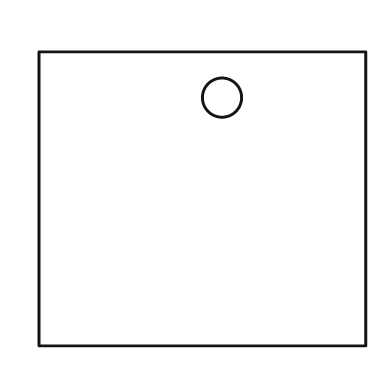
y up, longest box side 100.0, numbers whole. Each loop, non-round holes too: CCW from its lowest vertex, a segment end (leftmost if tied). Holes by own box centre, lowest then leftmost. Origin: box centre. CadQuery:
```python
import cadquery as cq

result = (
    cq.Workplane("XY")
    .moveTo(-50.0, -45.0)
    .lineTo(50.0, -45.0)
    .lineTo(50.0, 45.0)
    .lineTo(-50.0, 45.0)
    .close()
    .moveTo(6.0, 31.0)
    .circle(6.0)
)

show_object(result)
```